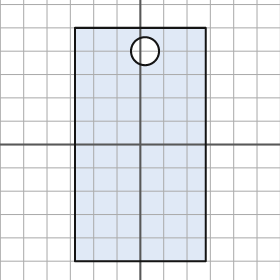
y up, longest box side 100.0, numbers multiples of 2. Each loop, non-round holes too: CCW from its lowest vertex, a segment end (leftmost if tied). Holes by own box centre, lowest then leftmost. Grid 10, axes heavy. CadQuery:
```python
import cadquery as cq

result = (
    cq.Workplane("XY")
    .moveTo(-28.0, -50.0)
    .lineTo(28.0, -50.0)
    .lineTo(28.0, 50.0)
    .lineTo(-28.0, 50.0)
    .close()
    .moveTo(2.0, 40.0)
    .circle(6.0)
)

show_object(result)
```